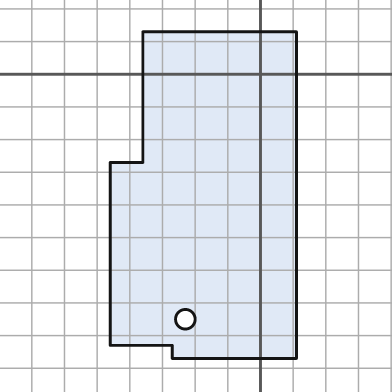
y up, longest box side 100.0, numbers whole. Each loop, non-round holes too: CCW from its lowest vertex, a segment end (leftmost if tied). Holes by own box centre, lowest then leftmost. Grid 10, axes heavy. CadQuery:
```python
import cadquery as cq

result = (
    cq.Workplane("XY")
    .moveTo(-27.0, -87.0)
    .lineTo(11.0, -87.0)
    .lineTo(11.0, 13.0)
    .lineTo(-36.0, 13.0)
    .lineTo(-36.0, -27.0)
    .lineTo(-46.0, -27.0)
    .lineTo(-46.0, -83.0)
    .lineTo(-27.0, -83.0)
    .close()
    .moveTo(-23.0, -75.0)
    .circle(3.0)
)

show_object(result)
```